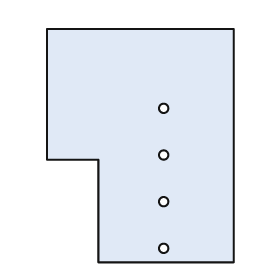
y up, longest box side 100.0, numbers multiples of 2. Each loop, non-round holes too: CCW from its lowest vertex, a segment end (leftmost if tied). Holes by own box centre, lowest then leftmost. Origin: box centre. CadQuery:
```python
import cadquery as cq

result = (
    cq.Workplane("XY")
    .moveTo(-18.0, -50.0)
    .lineTo(40.0, -50.0)
    .lineTo(40.0, 50.0)
    .lineTo(-40.0, 50.0)
    .lineTo(-40.0, -6.0)
    .lineTo(-18.0, -6.0)
    .close()
    .moveTo(10.0, -44.0)
    .circle(2.0)
    .moveTo(10.0, -24.0)
    .circle(2.0)
    .moveTo(10.0, -4.0)
    .circle(2.0)
    .moveTo(10.0, 16.0)
    .circle(2.0)
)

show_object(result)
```